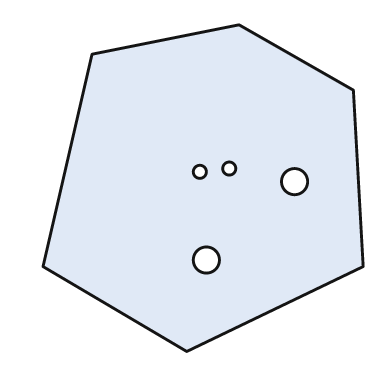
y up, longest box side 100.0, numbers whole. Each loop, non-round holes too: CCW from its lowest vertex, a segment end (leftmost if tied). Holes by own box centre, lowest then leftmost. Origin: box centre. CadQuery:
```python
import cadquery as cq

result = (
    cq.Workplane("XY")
    .moveTo(-5.0, -50.0)
    .lineTo(49.0, -24.0)
    .lineTo(46.0, 30.0)
    .lineTo(11.0, 50.0)
    .lineTo(-34.0, 41.0)
    .lineTo(-49.0, -24.0)
    .close()
    .moveTo(1.0, -22.0)
    .circle(4.0)
    .moveTo(28.0, 2.0)
    .circle(4.0)
    .moveTo(-1.0, 5.0)
    .circle(2.0)
    .moveTo(8.0, 6.0)
    .circle(2.0)
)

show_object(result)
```